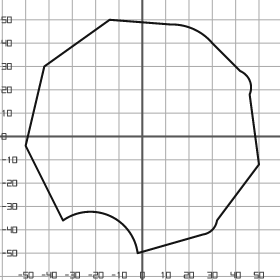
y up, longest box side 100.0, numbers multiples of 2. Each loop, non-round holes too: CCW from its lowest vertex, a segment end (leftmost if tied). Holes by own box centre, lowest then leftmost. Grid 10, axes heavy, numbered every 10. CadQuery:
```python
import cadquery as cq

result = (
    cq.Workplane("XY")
    .moveTo(-2.0, -50.0)
    .lineTo(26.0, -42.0)
    .threePointArc((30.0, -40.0), (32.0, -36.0))
    .lineTo(50.0, -12.0)
    .lineTo(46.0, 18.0)
    .threePointArc((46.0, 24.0), (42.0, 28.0))
    .lineTo(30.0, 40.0)
    .threePointArc((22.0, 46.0), (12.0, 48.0))
    .lineTo(-14.0, 50.0)
    .lineTo(-42.0, 30.0)
    .lineTo(-50.0, -4.0)
    .lineTo(-34.0, -36.0)
    .threePointArc((-14.0, -34.0), (-2.0, -50.0))
    .close()
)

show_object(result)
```